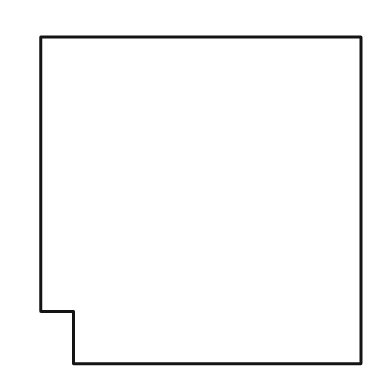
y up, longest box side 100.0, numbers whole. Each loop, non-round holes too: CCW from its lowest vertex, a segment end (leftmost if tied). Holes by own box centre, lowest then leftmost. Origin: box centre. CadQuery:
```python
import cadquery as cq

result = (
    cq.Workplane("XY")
    .moveTo(-39.0, -50.0)
    .lineTo(49.0, -50.0)
    .lineTo(49.0, 50.0)
    .lineTo(-49.0, 50.0)
    .lineTo(-49.0, -34.0)
    .lineTo(-39.0, -34.0)
    .close()
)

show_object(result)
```